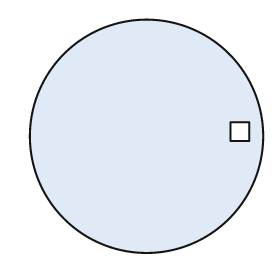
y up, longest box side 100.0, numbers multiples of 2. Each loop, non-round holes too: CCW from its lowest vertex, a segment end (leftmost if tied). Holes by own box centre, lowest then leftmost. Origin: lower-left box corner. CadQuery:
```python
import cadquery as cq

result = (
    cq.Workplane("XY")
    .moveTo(50.0, 50.0)
    .circle(50.0)
    .moveTo(86.0, 48.0)
    .lineTo(94.0, 48.0)
    .lineTo(94.0, 56.0)
    .lineTo(86.0, 56.0)
    .close()
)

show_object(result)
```